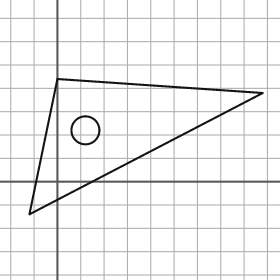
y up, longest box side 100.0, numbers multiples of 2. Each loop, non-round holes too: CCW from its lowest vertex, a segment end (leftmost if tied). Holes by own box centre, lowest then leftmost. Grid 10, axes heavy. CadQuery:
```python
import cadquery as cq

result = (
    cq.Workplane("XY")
    .moveTo(-12.0, -14.0)
    .lineTo(88.0, 38.0)
    .lineTo(0.0, 44.0)
    .close()
    .moveTo(12.0, 22.0)
    .circle(6.0)
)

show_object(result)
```